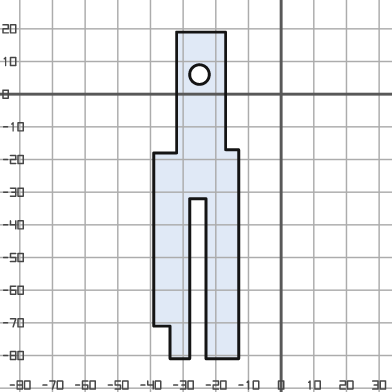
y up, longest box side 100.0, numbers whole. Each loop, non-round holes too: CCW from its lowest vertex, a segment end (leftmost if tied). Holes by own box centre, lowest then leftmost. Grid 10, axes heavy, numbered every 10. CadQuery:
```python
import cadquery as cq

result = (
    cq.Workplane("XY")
    .moveTo(-34.0, -81.0)
    .lineTo(-28.0, -81.0)
    .lineTo(-28.0, -32.0)
    .lineTo(-23.0, -32.0)
    .lineTo(-23.0, -81.0)
    .lineTo(-13.0, -81.0)
    .lineTo(-13.0, -17.0)
    .lineTo(-17.0, -17.0)
    .lineTo(-17.0, 19.0)
    .lineTo(-32.0, 19.0)
    .lineTo(-32.0, -18.0)
    .lineTo(-39.0, -18.0)
    .lineTo(-39.0, -71.0)
    .lineTo(-34.0, -71.0)
    .close()
    .moveTo(-25.0, 6.0)
    .circle(3.0)
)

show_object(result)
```